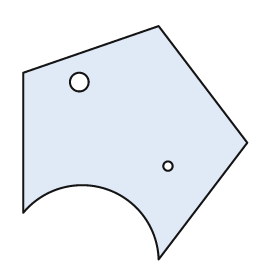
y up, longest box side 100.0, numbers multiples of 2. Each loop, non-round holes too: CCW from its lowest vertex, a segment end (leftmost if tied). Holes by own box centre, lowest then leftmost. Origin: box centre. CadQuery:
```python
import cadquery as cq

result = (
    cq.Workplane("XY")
    .moveTo(10.0, -50.0)
    .lineTo(48.0, 0.0)
    .lineTo(10.0, 50.0)
    .lineTo(-48.0, 30.0)
    .lineTo(-48.0, -30.0)
    .threePointArc((-12.0, -20.0), (10.0, -50.0))
    .close()
    .moveTo(14.0, -10.0)
    .circle(2.0)
    .moveTo(-24.0, 26.0)
    .circle(4.0)
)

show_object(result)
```